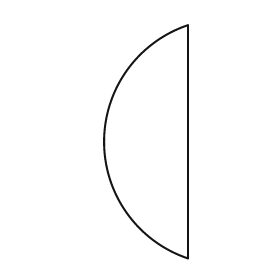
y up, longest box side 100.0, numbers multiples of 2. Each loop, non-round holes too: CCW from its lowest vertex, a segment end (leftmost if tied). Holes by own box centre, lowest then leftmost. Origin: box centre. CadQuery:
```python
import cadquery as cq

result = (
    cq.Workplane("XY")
    .moveTo(18.0, -50.0)
    .lineTo(18.0, 50.0)
    .threePointArc((-18.0, 0.0), (18.0, -50.0))
    .close()
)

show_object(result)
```